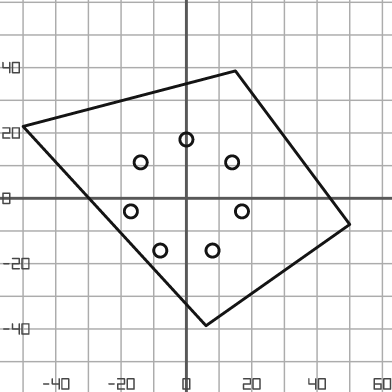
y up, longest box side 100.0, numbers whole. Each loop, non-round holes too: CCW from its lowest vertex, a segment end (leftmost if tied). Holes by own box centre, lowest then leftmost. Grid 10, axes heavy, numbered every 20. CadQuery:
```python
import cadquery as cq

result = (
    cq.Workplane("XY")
    .moveTo(6.0, -39.0)
    .lineTo(50.0, -8.0)
    .lineTo(15.0, 39.0)
    .lineTo(-50.0, 22.0)
    .close()
    .moveTo(-8.0, -16.0)
    .circle(2.0)
    .moveTo(8.0, -16.0)
    .circle(2.0)
    .moveTo(-17.0, -4.0)
    .circle(2.0)
    .moveTo(17.0, -4.0)
    .circle(2.0)
    .moveTo(-14.0, 11.0)
    .circle(2.0)
    .moveTo(14.0, 11.0)
    .circle(2.0)
    .moveTo(0.0, 18.0)
    .circle(2.0)
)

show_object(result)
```